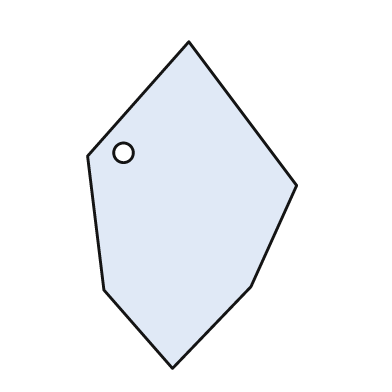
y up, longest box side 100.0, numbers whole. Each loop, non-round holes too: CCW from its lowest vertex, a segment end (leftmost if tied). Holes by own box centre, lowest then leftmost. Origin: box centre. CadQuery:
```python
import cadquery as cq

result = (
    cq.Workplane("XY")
    .moveTo(-6.0, -50.0)
    .lineTo(18.0, -25.0)
    .lineTo(32.0, 6.0)
    .lineTo(-1.0, 50.0)
    .lineTo(-32.0, 15.0)
    .lineTo(-27.0, -26.0)
    .close()
    .moveTo(-21.0, 16.0)
    .circle(3.0)
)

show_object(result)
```